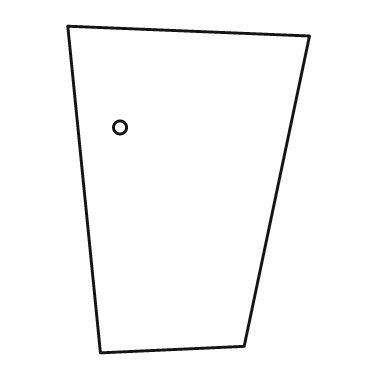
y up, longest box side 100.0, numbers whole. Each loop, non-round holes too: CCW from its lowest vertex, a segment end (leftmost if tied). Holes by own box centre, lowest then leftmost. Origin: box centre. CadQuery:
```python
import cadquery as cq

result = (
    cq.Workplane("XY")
    .moveTo(-27.0, -50.0)
    .lineTo(17.0, -48.0)
    .lineTo(37.0, 47.0)
    .lineTo(-37.0, 50.0)
    .close()
    .moveTo(-21.0, 19.0)
    .circle(2.0)
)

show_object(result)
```